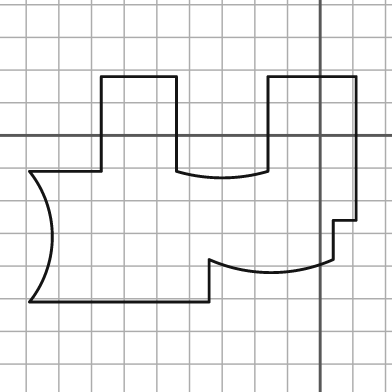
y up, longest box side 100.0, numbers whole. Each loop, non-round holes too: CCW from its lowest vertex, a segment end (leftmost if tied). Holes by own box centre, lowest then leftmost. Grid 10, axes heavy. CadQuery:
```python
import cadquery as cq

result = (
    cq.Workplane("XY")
    .moveTo(-89.0, -51.0)
    .lineTo(-34.0, -51.0)
    .lineTo(-34.0, -38.0)
    .threePointArc((-15.0, -42.0), (4.0, -38.0))
    .lineTo(4.0, -26.0)
    .lineTo(11.0, -26.0)
    .lineTo(11.0, 18.0)
    .lineTo(-16.0, 18.0)
    .lineTo(-16.0, -11.0)
    .threePointArc((-30.0, -13.0), (-44.0, -11.0))
    .lineTo(-44.0, 18.0)
    .lineTo(-67.0, 18.0)
    .lineTo(-67.0, -11.0)
    .lineTo(-89.0, -11.0)
    .threePointArc((-82.0, -31.0), (-89.0, -51.0))
    .close()
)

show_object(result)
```